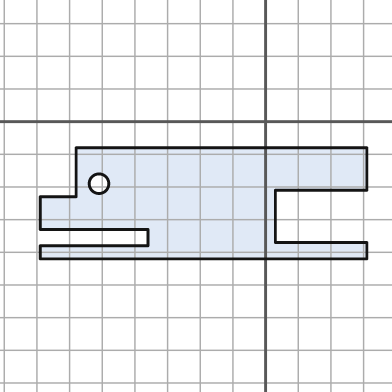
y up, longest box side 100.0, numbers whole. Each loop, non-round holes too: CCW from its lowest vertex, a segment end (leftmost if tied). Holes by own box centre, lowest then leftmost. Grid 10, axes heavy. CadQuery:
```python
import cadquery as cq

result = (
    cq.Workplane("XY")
    .moveTo(-69.0, -42.0)
    .lineTo(31.0, -42.0)
    .lineTo(31.0, -37.0)
    .lineTo(3.0, -37.0)
    .lineTo(3.0, -21.0)
    .lineTo(31.0, -21.0)
    .lineTo(31.0, -8.0)
    .lineTo(-58.0, -8.0)
    .lineTo(-58.0, -23.0)
    .lineTo(-69.0, -23.0)
    .lineTo(-69.0, -33.0)
    .lineTo(-36.0, -33.0)
    .lineTo(-36.0, -38.0)
    .lineTo(-69.0, -38.0)
    .close()
    .moveTo(-51.0, -19.0)
    .circle(3.0)
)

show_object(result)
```